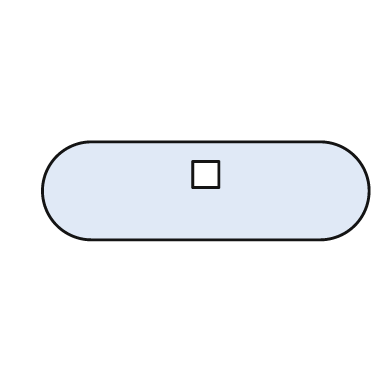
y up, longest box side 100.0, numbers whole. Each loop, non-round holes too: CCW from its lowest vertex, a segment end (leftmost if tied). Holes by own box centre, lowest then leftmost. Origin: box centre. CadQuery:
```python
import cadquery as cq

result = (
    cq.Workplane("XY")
    .moveTo(-35.0, -15.0)
    .lineTo(35.0, -15.0)
    .threePointArc((50.0, 0.0), (35.0, 15.0))
    .lineTo(-35.0, 15.0)
    .threePointArc((-50.0, 0.0), (-35.0, -15.0))
    .close()
    .moveTo(-4.0, 1.0)
    .lineTo(4.0, 1.0)
    .lineTo(4.0, 9.0)
    .lineTo(-4.0, 9.0)
    .close()
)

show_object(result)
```